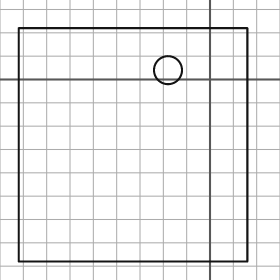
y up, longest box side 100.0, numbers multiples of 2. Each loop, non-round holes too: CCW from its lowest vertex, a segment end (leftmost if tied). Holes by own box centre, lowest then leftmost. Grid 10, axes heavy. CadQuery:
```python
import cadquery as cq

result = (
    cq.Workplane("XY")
    .moveTo(-82.0, -78.0)
    .lineTo(16.0, -78.0)
    .lineTo(16.0, 22.0)
    .lineTo(-82.0, 22.0)
    .close()
    .moveTo(-18.0, 4.0)
    .circle(6.0)
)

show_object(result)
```